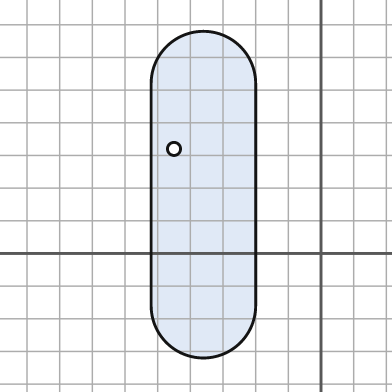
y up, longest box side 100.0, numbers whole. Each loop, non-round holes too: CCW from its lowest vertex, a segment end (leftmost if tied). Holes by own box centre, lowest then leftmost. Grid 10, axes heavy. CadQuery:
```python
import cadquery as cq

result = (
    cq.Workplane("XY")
    .moveTo(-52.0, -16.0)
    .threePointArc((-36.0, -32.0), (-20.0, -16.0))
    .lineTo(-20.0, 52.0)
    .threePointArc((-36.0, 68.0), (-52.0, 52.0))
    .close()
    .moveTo(-45.0, 32.0)
    .circle(2.0)
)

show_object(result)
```